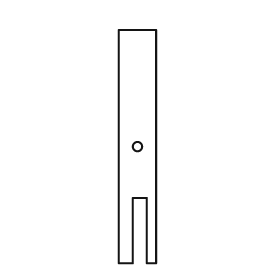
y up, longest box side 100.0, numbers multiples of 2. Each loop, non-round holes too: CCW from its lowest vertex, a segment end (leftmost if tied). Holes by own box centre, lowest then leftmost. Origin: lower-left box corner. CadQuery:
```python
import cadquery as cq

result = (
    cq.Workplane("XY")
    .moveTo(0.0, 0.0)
    .lineTo(6.0, 0.0)
    .lineTo(6.0, 28.0)
    .lineTo(12.0, 28.0)
    .lineTo(12.0, 0.0)
    .lineTo(16.0, 0.0)
    .lineTo(16.0, 100.0)
    .lineTo(0.0, 100.0)
    .close()
    .moveTo(8.0, 50.0)
    .circle(2.0)
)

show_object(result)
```